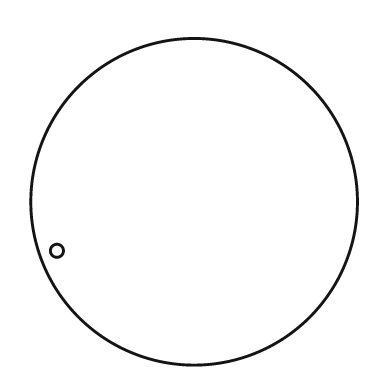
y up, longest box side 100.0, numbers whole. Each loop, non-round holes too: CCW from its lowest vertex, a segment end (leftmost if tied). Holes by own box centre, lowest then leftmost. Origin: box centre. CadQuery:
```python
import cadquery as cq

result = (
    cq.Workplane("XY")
    .moveTo(0.0, 0.0)
    .circle(50.0)
    .moveTo(-42.0, -15.0)
    .circle(2.0)
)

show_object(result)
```